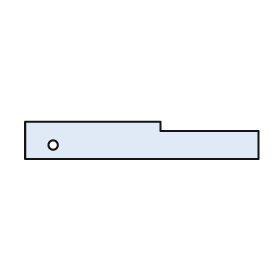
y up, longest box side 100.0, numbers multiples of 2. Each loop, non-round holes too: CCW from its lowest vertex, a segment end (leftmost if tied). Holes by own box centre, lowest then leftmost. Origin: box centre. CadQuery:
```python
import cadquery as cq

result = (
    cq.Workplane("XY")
    .moveTo(-50.0, -8.0)
    .lineTo(50.0, -8.0)
    .lineTo(50.0, 4.0)
    .lineTo(8.0, 4.0)
    .lineTo(8.0, 8.0)
    .lineTo(-50.0, 8.0)
    .close()
    .moveTo(-38.0, -2.0)
    .circle(2.0)
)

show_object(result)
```